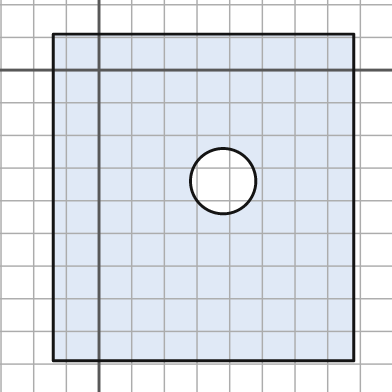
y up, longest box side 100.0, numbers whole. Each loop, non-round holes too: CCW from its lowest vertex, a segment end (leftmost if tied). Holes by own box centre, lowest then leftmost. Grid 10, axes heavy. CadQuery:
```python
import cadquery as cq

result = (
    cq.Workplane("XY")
    .moveTo(-14.0, -89.0)
    .lineTo(78.0, -89.0)
    .lineTo(78.0, 11.0)
    .lineTo(-14.0, 11.0)
    .close()
    .moveTo(38.0, -34.0)
    .circle(10.0)
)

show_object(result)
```